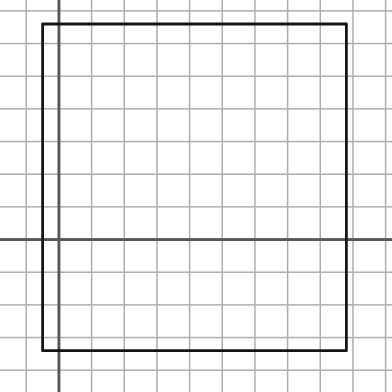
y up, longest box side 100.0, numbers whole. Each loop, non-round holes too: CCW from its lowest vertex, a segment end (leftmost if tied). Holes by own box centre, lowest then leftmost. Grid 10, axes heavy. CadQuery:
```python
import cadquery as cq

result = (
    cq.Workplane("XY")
    .moveTo(-5.0, -34.0)
    .lineTo(88.0, -34.0)
    .lineTo(88.0, 66.0)
    .lineTo(-5.0, 66.0)
    .close()
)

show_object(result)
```